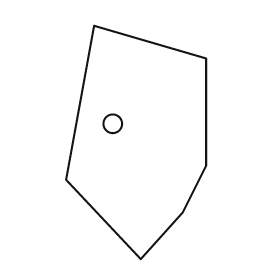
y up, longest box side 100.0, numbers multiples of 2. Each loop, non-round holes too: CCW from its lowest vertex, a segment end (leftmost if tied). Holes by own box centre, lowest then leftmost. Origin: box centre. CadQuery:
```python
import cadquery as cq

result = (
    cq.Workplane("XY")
    .moveTo(2.0, -50.0)
    .lineTo(20.0, -30.0)
    .lineTo(30.0, -10.0)
    .lineTo(30.0, 36.0)
    .lineTo(-18.0, 50.0)
    .lineTo(-30.0, -16.0)
    .close()
    .moveTo(-10.0, 8.0)
    .circle(4.0)
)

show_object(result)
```